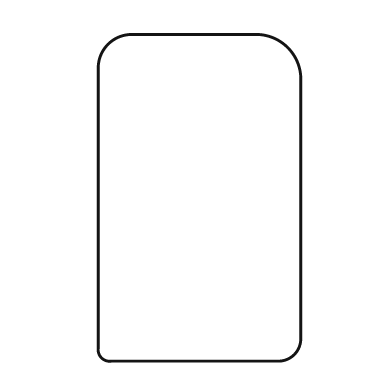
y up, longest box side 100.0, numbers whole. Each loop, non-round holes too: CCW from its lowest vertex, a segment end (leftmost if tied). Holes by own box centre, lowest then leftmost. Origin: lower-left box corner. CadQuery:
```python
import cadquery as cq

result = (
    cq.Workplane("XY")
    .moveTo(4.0, 0.0)
    .lineTo(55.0, 0.0)
    .threePointArc((60.0, 2.0), (62.0, 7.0))
    .lineTo(62.0, 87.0)
    .threePointArc((58.0, 96.0), (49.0, 100.0))
    .lineTo(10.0, 100.0)
    .threePointArc((3.0, 97.0), (0.0, 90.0))
    .lineTo(0.0, 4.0)
    .threePointArc((1.0, 1.0), (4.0, 0.0))
    .close()
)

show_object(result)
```